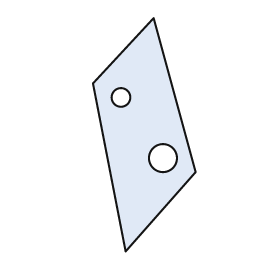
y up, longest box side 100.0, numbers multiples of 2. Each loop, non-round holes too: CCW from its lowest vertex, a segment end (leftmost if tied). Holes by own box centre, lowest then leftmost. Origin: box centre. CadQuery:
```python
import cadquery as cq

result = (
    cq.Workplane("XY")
    .moveTo(-8.0, -50.0)
    .lineTo(22.0, -16.0)
    .lineTo(4.0, 50.0)
    .lineTo(-22.0, 22.0)
    .close()
    .moveTo(8.0, -10.0)
    .circle(6.0)
    .moveTo(-10.0, 16.0)
    .circle(4.0)
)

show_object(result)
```